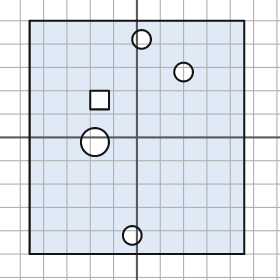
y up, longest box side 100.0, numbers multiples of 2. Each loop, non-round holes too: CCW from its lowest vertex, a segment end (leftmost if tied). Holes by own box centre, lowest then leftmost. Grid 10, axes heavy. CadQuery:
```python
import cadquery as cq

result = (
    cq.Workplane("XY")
    .moveTo(-46.0, -50.0)
    .lineTo(46.0, -50.0)
    .lineTo(46.0, 50.0)
    .lineTo(-46.0, 50.0)
    .close()
    .moveTo(-2.0, -42.0)
    .circle(4.0)
    .moveTo(-18.0, -2.0)
    .circle(6.0)
    .moveTo(-20.0, 12.0)
    .lineTo(-12.0, 12.0)
    .lineTo(-12.0, 20.0)
    .lineTo(-20.0, 20.0)
    .close()
    .moveTo(20.0, 28.0)
    .circle(4.0)
    .moveTo(2.0, 42.0)
    .circle(4.0)
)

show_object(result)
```